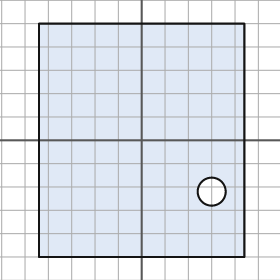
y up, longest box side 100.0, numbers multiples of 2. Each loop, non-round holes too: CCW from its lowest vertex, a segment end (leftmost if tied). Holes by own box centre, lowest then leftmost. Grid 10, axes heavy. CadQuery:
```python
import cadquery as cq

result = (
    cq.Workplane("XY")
    .moveTo(-44.0, -50.0)
    .lineTo(44.0, -50.0)
    .lineTo(44.0, 50.0)
    .lineTo(-44.0, 50.0)
    .close()
    .moveTo(30.0, -22.0)
    .circle(6.0)
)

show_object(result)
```